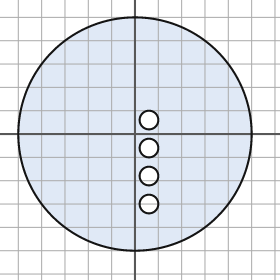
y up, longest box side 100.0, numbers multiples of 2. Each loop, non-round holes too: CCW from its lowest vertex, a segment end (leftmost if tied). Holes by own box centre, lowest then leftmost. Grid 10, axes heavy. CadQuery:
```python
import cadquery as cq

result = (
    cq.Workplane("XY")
    .moveTo(0.0, 0.0)
    .circle(50.0)
    .moveTo(6.0, -30.0)
    .circle(4.0)
    .moveTo(6.0, -18.0)
    .circle(4.0)
    .moveTo(6.0, -6.0)
    .circle(4.0)
    .moveTo(6.0, 6.0)
    .circle(4.0)
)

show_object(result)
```